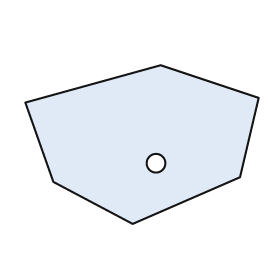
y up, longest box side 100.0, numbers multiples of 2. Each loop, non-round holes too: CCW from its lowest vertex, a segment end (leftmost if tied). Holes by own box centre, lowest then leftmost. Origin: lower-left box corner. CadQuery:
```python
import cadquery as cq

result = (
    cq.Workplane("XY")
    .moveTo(46.0, 0.0)
    .lineTo(92.0, 20.0)
    .lineTo(100.0, 54.0)
    .lineTo(58.0, 68.0)
    .lineTo(0.0, 52.0)
    .lineTo(12.0, 18.0)
    .close()
    .moveTo(56.0, 26.0)
    .circle(4.0)
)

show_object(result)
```